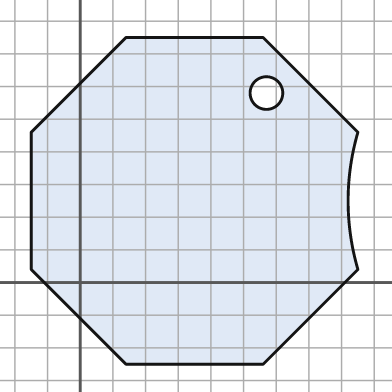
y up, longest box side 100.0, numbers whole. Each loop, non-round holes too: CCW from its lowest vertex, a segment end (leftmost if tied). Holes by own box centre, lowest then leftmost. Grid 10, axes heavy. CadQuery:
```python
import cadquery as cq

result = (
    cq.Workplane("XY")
    .moveTo(14.0, -25.0)
    .lineTo(56.0, -25.0)
    .lineTo(85.0, 4.0)
    .threePointArc((82.0, 25.0), (85.0, 46.0))
    .lineTo(56.0, 75.0)
    .lineTo(14.0, 75.0)
    .lineTo(-15.0, 46.0)
    .lineTo(-15.0, 4.0)
    .close()
    .moveTo(57.0, 58.0)
    .circle(5.0)
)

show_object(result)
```